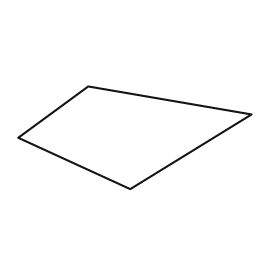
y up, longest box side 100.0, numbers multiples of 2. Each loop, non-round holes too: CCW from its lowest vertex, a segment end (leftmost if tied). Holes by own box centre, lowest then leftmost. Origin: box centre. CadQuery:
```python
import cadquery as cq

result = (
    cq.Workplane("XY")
    .moveTo(-2.0, -22.0)
    .lineTo(50.0, 10.0)
    .lineTo(-20.0, 22.0)
    .lineTo(-50.0, 0.0)
    .close()
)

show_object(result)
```